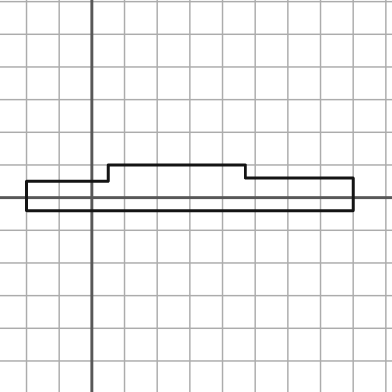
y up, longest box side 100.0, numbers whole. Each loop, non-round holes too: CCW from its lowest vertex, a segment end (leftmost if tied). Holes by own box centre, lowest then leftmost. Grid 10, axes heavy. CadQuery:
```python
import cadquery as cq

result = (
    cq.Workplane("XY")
    .moveTo(-20.0, -4.0)
    .lineTo(80.0, -4.0)
    .lineTo(80.0, 6.0)
    .lineTo(47.0, 6.0)
    .lineTo(47.0, 10.0)
    .lineTo(5.0, 10.0)
    .lineTo(5.0, 5.0)
    .lineTo(-20.0, 5.0)
    .close()
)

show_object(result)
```